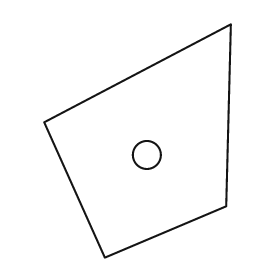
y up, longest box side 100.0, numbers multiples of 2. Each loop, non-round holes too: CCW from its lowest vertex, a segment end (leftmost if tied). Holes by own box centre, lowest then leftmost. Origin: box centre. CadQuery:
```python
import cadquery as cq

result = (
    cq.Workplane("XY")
    .moveTo(-14.0, -50.0)
    .lineTo(38.0, -28.0)
    .lineTo(40.0, 50.0)
    .lineTo(-40.0, 8.0)
    .close()
    .moveTo(4.0, -6.0)
    .circle(6.0)
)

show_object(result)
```